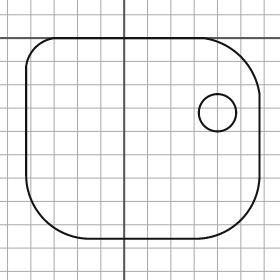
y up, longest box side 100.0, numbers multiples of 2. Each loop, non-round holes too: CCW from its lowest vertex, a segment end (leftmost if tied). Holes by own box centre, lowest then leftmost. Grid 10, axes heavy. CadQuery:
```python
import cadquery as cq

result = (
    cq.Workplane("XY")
    .moveTo(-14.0, -86.0)
    .lineTo(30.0, -86.0)
    .threePointArc((50.0, -78.0), (58.0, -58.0))
    .lineTo(58.0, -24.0)
    .threePointArc((50.0, -8.0), (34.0, 0.0))
    .lineTo(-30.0, 0.0)
    .threePointArc((-38.0, -4.0), (-42.0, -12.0))
    .lineTo(-42.0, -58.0)
    .threePointArc((-34.0, -78.0), (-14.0, -86.0))
    .close()
    .moveTo(40.0, -32.0)
    .circle(8.0)
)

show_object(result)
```